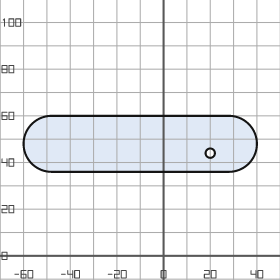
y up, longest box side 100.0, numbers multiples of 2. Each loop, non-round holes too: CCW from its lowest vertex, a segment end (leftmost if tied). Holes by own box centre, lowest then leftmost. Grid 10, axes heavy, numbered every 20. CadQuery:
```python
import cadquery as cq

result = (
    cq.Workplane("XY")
    .moveTo(-48.0, 36.0)
    .lineTo(28.0, 36.0)
    .threePointArc((40.0, 48.0), (28.0, 60.0))
    .lineTo(-48.0, 60.0)
    .threePointArc((-60.0, 48.0), (-48.0, 36.0))
    .close()
    .moveTo(20.0, 44.0)
    .circle(2.0)
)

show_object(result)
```